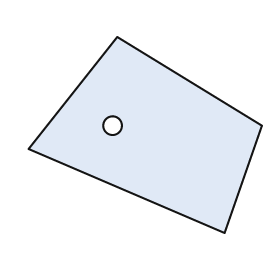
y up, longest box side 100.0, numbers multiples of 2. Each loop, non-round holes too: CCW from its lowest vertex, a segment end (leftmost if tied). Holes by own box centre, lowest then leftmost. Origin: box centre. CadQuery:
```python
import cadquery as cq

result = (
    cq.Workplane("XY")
    .moveTo(34.0, -42.0)
    .lineTo(50.0, 4.0)
    .lineTo(-12.0, 42.0)
    .lineTo(-50.0, -6.0)
    .close()
    .moveTo(-14.0, 4.0)
    .circle(4.0)
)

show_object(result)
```